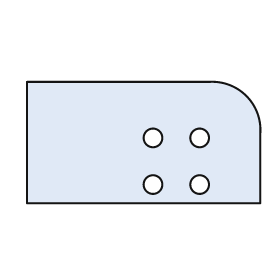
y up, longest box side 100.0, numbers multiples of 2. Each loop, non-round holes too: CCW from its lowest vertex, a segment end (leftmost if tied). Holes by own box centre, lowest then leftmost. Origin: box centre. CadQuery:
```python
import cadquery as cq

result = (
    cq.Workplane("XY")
    .moveTo(-50.0, -26.0)
    .lineTo(50.0, -26.0)
    .lineTo(50.0, 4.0)
    .threePointArc((44.0, 20.0), (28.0, 26.0))
    .lineTo(-50.0, 26.0)
    .close()
    .moveTo(4.0, -18.0)
    .circle(4.0)
    .moveTo(24.0, -18.0)
    .circle(4.0)
    .moveTo(4.0, 2.0)
    .circle(4.0)
    .moveTo(24.0, 2.0)
    .circle(4.0)
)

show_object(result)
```